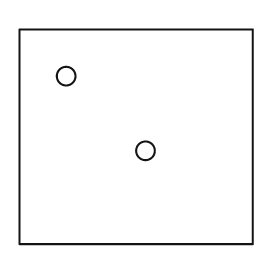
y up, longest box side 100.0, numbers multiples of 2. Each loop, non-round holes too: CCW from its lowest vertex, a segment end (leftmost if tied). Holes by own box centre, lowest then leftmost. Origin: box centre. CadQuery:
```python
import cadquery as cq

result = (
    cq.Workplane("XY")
    .moveTo(-50.0, -46.0)
    .lineTo(50.0, -46.0)
    .lineTo(50.0, 46.0)
    .lineTo(-50.0, 46.0)
    .close()
    .moveTo(4.0, -6.0)
    .circle(4.0)
    .moveTo(-30.0, 26.0)
    .circle(4.0)
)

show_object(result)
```